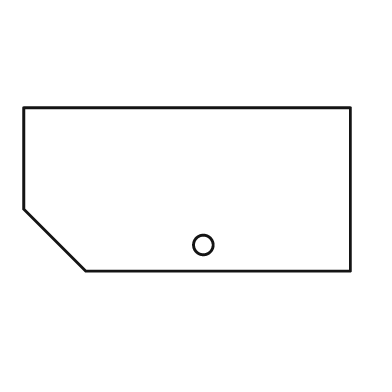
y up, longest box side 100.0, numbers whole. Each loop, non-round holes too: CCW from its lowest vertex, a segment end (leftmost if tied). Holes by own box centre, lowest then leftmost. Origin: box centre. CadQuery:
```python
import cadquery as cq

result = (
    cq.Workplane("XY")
    .moveTo(-31.0, -25.0)
    .lineTo(50.0, -25.0)
    .lineTo(50.0, 25.0)
    .lineTo(-50.0, 25.0)
    .lineTo(-50.0, -6.0)
    .close()
    .moveTo(5.0, -17.0)
    .circle(3.0)
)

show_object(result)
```